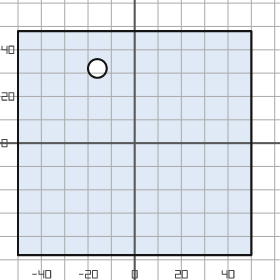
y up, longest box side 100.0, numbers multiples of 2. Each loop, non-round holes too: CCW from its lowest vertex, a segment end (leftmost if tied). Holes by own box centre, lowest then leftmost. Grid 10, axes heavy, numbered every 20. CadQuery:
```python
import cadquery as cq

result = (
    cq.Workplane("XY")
    .moveTo(-50.0, -48.0)
    .lineTo(50.0, -48.0)
    .lineTo(50.0, 48.0)
    .lineTo(-50.0, 48.0)
    .close()
    .moveTo(-16.0, 32.0)
    .circle(4.0)
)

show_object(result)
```